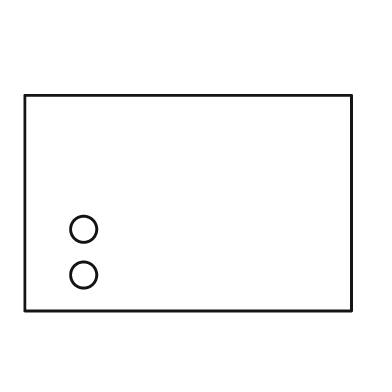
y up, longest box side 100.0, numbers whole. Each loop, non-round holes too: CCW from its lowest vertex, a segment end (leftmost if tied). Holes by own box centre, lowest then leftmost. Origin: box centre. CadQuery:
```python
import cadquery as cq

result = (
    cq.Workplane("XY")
    .moveTo(-50.0, -33.0)
    .lineTo(50.0, -33.0)
    .lineTo(50.0, 33.0)
    .lineTo(-50.0, 33.0)
    .close()
    .moveTo(-32.0, -22.0)
    .circle(4.0)
    .moveTo(-32.0, -8.0)
    .circle(4.0)
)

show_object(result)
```